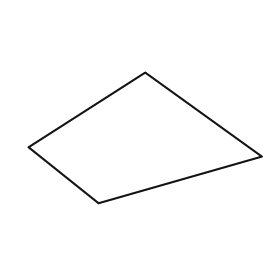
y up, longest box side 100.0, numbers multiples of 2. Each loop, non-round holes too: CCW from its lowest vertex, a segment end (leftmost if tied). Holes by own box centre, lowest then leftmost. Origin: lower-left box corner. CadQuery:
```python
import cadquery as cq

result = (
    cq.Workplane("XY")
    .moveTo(30.0, 0.0)
    .lineTo(100.0, 20.0)
    .lineTo(50.0, 56.0)
    .lineTo(0.0, 24.0)
    .close()
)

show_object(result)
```